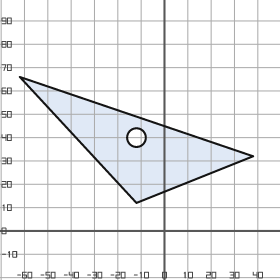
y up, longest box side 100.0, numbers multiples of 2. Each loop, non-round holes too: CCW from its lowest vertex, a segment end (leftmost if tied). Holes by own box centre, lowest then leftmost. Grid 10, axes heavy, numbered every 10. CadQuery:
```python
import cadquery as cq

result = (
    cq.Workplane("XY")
    .moveTo(-12.0, 12.0)
    .lineTo(38.0, 32.0)
    .lineTo(-62.0, 66.0)
    .close()
    .moveTo(-12.0, 40.0)
    .circle(4.0)
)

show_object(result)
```